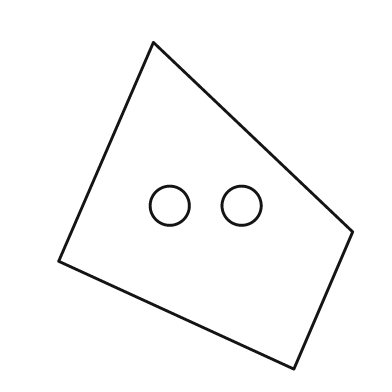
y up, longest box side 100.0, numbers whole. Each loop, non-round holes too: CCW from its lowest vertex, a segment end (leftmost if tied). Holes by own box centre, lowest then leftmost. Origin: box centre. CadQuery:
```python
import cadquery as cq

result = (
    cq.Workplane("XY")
    .moveTo(27.0, -50.0)
    .lineTo(45.0, -8.0)
    .lineTo(-16.0, 50.0)
    .lineTo(-45.0, -17.0)
    .close()
    .moveTo(-11.0, 0.0)
    .circle(6.0)
    .moveTo(11.0, 0.0)
    .circle(6.0)
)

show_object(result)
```